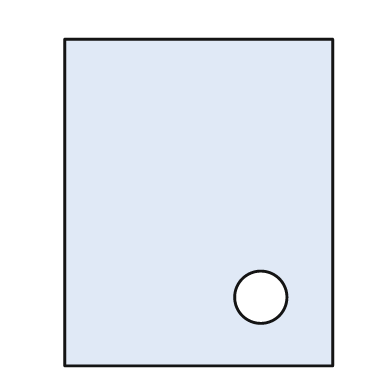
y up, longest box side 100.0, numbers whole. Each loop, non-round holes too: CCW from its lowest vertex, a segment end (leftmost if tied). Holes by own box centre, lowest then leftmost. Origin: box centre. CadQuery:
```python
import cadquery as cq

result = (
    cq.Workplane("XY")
    .moveTo(-41.0, -50.0)
    .lineTo(41.0, -50.0)
    .lineTo(41.0, 50.0)
    .lineTo(-41.0, 50.0)
    .close()
    .moveTo(19.0, -29.0)
    .circle(8.0)
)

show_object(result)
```